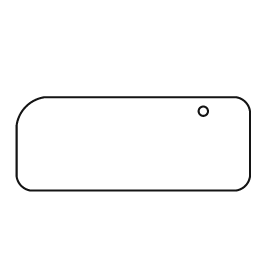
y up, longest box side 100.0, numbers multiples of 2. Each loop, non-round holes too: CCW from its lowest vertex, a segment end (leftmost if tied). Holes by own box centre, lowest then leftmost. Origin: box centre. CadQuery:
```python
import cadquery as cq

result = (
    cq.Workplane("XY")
    .moveTo(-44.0, -20.0)
    .lineTo(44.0, -20.0)
    .threePointArc((48.0, -18.0), (50.0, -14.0))
    .lineTo(50.0, 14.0)
    .threePointArc((48.0, 18.0), (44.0, 20.0))
    .lineTo(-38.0, 20.0)
    .threePointArc((-46.0, 16.0), (-50.0, 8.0))
    .lineTo(-50.0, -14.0)
    .threePointArc((-48.0, -18.0), (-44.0, -20.0))
    .close()
    .moveTo(30.0, 14.0)
    .circle(2.0)
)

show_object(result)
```